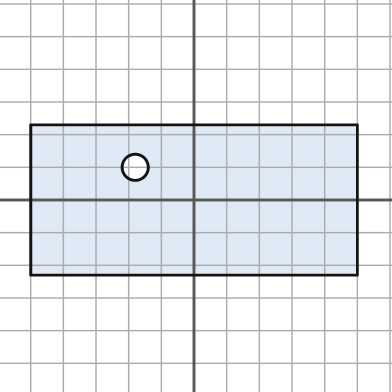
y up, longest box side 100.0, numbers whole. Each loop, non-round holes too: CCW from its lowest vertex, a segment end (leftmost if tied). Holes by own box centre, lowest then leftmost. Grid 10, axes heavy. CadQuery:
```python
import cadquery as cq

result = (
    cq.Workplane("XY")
    .moveTo(-50.0, -23.0)
    .lineTo(50.0, -23.0)
    .lineTo(50.0, 23.0)
    .lineTo(-50.0, 23.0)
    .close()
    .moveTo(-18.0, 10.0)
    .circle(4.0)
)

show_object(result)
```